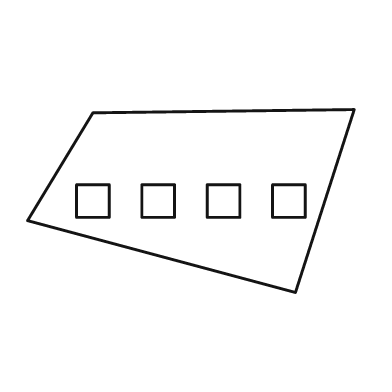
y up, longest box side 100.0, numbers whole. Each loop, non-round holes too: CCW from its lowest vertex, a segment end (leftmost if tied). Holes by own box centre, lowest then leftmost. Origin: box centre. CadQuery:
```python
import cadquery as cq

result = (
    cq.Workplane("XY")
    .moveTo(32.0, -28.0)
    .lineTo(50.0, 28.0)
    .lineTo(-30.0, 27.0)
    .lineTo(-50.0, -6.0)
    .close()
    .moveTo(-35.0, -5.0)
    .lineTo(-25.0, -5.0)
    .lineTo(-25.0, 5.0)
    .lineTo(-35.0, 5.0)
    .close()
    .moveTo(-15.0, -5.0)
    .lineTo(-5.0, -5.0)
    .lineTo(-5.0, 5.0)
    .lineTo(-15.0, 5.0)
    .close()
    .moveTo(5.0, -5.0)
    .lineTo(15.0, -5.0)
    .lineTo(15.0, 5.0)
    .lineTo(5.0, 5.0)
    .close()
    .moveTo(25.0, -5.0)
    .lineTo(35.0, -5.0)
    .lineTo(35.0, 5.0)
    .lineTo(25.0, 5.0)
    .close()
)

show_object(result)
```